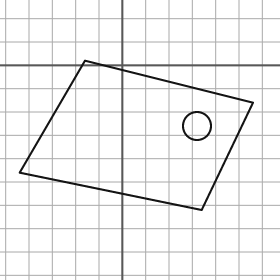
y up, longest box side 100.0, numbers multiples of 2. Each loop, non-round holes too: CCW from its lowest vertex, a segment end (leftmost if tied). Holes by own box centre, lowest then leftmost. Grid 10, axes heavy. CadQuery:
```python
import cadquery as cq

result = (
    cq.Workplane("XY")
    .moveTo(34.0, -62.0)
    .lineTo(56.0, -16.0)
    .lineTo(-16.0, 2.0)
    .lineTo(-44.0, -46.0)
    .close()
    .moveTo(32.0, -26.0)
    .circle(6.0)
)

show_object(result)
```